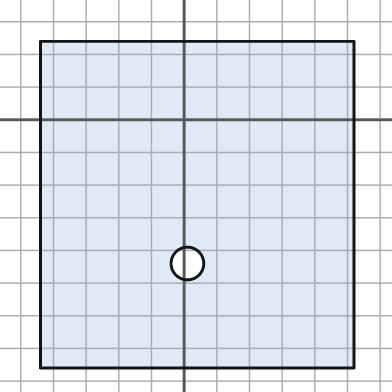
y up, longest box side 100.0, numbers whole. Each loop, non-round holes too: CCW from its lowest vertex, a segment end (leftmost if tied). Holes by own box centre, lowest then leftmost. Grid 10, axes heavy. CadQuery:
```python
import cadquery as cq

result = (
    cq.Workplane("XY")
    .moveTo(-44.0, -76.0)
    .lineTo(52.0, -76.0)
    .lineTo(52.0, 24.0)
    .lineTo(-44.0, 24.0)
    .close()
    .moveTo(1.0, -44.0)
    .circle(5.0)
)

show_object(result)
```